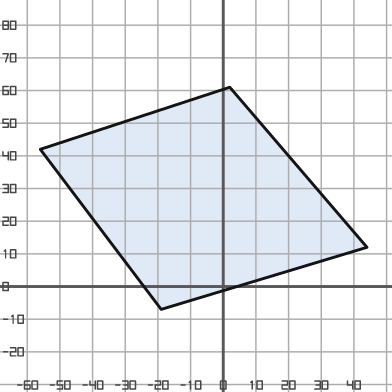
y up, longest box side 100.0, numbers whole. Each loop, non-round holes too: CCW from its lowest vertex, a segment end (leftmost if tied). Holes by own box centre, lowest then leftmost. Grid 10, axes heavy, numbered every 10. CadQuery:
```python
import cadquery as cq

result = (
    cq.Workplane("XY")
    .moveTo(-19.0, -7.0)
    .lineTo(44.0, 12.0)
    .lineTo(2.0, 61.0)
    .lineTo(-56.0, 42.0)
    .close()
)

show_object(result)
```